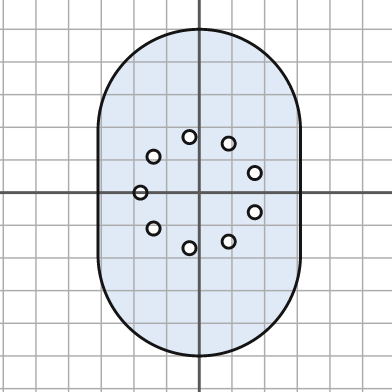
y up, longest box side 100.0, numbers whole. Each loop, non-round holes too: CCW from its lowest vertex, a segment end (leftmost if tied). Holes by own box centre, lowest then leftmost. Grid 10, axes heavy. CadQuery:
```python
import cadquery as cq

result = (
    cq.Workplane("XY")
    .moveTo(-31.0, -19.0)
    .threePointArc((0.0, -50.0), (31.0, -19.0))
    .lineTo(31.0, 19.0)
    .threePointArc((0.0, 50.0), (-31.0, 19.0))
    .close()
    .moveTo(-3.0, -17.0)
    .circle(2.0)
    .moveTo(9.0, -15.0)
    .circle(2.0)
    .moveTo(-14.0, -11.0)
    .circle(2.0)
    .moveTo(17.0, -6.0)
    .circle(2.0)
    .moveTo(-18.0, 0.0)
    .circle(2.0)
    .moveTo(17.0, 6.0)
    .circle(2.0)
    .moveTo(-14.0, 11.0)
    .circle(2.0)
    .moveTo(9.0, 15.0)
    .circle(2.0)
    .moveTo(-3.0, 17.0)
    .circle(2.0)
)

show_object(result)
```